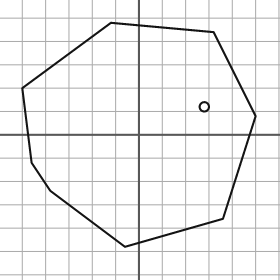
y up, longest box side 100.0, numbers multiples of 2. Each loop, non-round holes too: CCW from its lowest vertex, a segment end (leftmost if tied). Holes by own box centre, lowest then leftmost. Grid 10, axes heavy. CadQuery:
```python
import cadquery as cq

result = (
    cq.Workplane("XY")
    .moveTo(-6.0, -48.0)
    .lineTo(36.0, -36.0)
    .lineTo(50.0, 8.0)
    .lineTo(32.0, 44.0)
    .lineTo(-12.0, 48.0)
    .lineTo(-50.0, 20.0)
    .lineTo(-46.0, -12.0)
    .lineTo(-38.0, -24.0)
    .close()
    .moveTo(28.0, 12.0)
    .circle(2.0)
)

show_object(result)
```